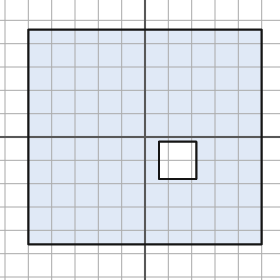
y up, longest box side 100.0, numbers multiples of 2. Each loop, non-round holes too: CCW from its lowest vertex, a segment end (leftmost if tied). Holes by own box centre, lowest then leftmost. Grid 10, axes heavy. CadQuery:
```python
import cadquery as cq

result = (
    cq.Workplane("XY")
    .moveTo(-50.0, -46.0)
    .lineTo(50.0, -46.0)
    .lineTo(50.0, 46.0)
    .lineTo(-50.0, 46.0)
    .close()
    .moveTo(6.0, -18.0)
    .lineTo(22.0, -18.0)
    .lineTo(22.0, -2.0)
    .lineTo(6.0, -2.0)
    .close()
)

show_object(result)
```